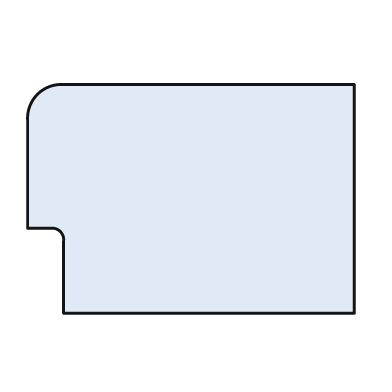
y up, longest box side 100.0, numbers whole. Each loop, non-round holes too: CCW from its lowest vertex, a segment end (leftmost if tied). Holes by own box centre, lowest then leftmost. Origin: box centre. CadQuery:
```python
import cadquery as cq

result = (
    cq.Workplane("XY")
    .moveTo(-39.0, -35.0)
    .lineTo(50.0, -35.0)
    .lineTo(50.0, 35.0)
    .lineTo(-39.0, 35.0)
    .threePointArc((-47.0, 32.0), (-50.0, 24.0))
    .lineTo(-50.0, -9.0)
    .lineTo(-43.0, -9.0)
    .threePointArc((-40.0, -10.0), (-39.0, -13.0))
    .close()
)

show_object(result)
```